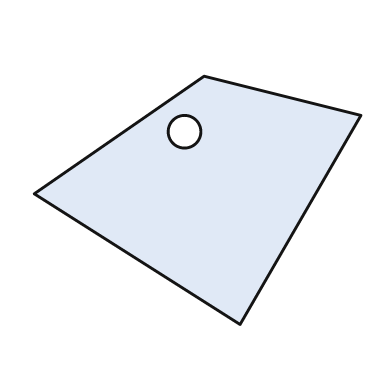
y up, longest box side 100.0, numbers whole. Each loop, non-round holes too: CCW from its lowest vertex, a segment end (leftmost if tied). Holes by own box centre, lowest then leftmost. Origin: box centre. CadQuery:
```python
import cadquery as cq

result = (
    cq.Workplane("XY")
    .moveTo(13.0, -38.0)
    .lineTo(50.0, 26.0)
    .lineTo(2.0, 38.0)
    .lineTo(-50.0, 2.0)
    .close()
    .moveTo(-4.0, 21.0)
    .circle(5.0)
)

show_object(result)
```